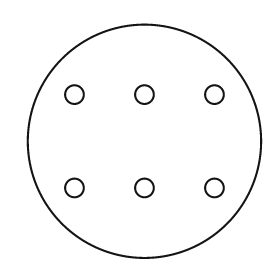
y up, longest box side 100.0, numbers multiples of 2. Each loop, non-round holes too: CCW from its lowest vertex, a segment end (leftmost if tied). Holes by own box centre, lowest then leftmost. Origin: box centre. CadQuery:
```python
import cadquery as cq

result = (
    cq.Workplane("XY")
    .moveTo(0.0, 0.0)
    .circle(50.0)
    .moveTo(-30.0, -20.0)
    .circle(4.0)
    .moveTo(0.0, -20.0)
    .circle(4.0)
    .moveTo(30.0, -20.0)
    .circle(4.0)
    .moveTo(-30.0, 20.0)
    .circle(4.0)
    .moveTo(0.0, 20.0)
    .circle(4.0)
    .moveTo(30.0, 20.0)
    .circle(4.0)
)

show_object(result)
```